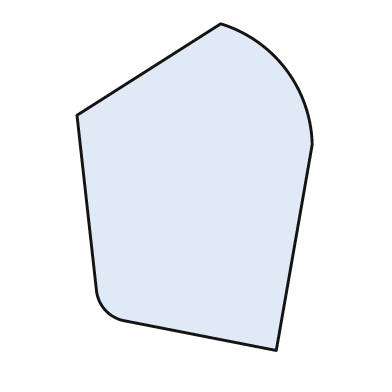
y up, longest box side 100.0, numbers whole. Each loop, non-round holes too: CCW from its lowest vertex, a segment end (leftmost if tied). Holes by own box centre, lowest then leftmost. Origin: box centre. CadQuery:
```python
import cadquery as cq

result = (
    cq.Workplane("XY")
    .moveTo(25.0, -50.0)
    .lineTo(36.0, 13.0)
    .threePointArc((28.0, 36.0), (8.0, 50.0))
    .lineTo(-36.0, 22.0)
    .lineTo(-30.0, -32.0)
    .threePointArc((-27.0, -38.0), (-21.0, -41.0))
    .close()
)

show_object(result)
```